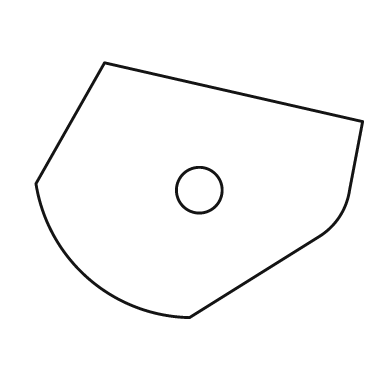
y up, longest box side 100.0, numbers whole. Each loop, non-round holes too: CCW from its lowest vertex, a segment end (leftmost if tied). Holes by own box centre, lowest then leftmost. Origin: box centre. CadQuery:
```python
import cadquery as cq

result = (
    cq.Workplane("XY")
    .moveTo(-3.0, -39.0)
    .lineTo(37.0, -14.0)
    .threePointArc((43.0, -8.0), (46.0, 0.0))
    .lineTo(50.0, 21.0)
    .lineTo(-29.0, 39.0)
    .lineTo(-50.0, 2.0)
    .threePointArc((-34.0, -27.0), (-3.0, -39.0))
    .close()
    .moveTo(0.0, 0.0)
    .circle(7.0)
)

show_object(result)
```